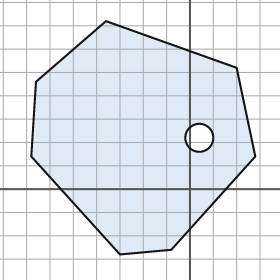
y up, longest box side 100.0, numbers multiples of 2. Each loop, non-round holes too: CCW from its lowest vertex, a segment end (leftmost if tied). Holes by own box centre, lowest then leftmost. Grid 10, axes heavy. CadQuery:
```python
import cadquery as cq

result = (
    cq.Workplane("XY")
    .moveTo(-30.0, -28.0)
    .lineTo(-8.0, -26.0)
    .lineTo(28.0, 14.0)
    .lineTo(20.0, 52.0)
    .lineTo(-36.0, 72.0)
    .lineTo(-66.0, 46.0)
    .lineTo(-68.0, 14.0)
    .close()
    .moveTo(4.0, 22.0)
    .circle(6.0)
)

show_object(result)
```